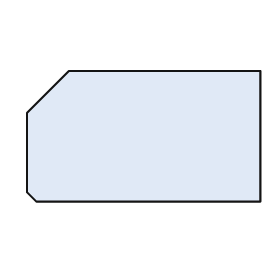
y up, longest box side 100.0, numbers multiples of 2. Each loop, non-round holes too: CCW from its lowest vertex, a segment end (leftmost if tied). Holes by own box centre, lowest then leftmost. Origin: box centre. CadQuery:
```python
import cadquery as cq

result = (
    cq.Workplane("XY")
    .moveTo(-46.0, -28.0)
    .lineTo(50.0, -28.0)
    .lineTo(50.0, 28.0)
    .lineTo(-32.0, 28.0)
    .lineTo(-50.0, 10.0)
    .lineTo(-50.0, -24.0)
    .close()
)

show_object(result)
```